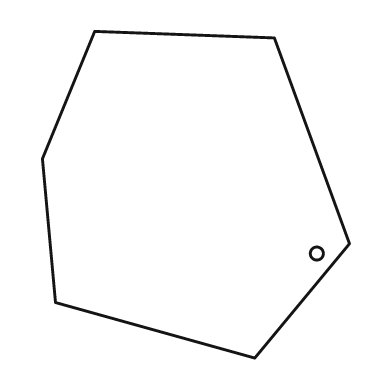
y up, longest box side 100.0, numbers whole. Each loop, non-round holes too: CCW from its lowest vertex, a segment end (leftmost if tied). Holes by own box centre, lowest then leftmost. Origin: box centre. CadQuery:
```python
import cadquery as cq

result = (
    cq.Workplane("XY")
    .moveTo(18.0, -50.0)
    .lineTo(47.0, -15.0)
    .lineTo(24.0, 48.0)
    .lineTo(-31.0, 50.0)
    .lineTo(-47.0, 11.0)
    .lineTo(-43.0, -33.0)
    .close()
    .moveTo(37.0, -18.0)
    .circle(2.0)
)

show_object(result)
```